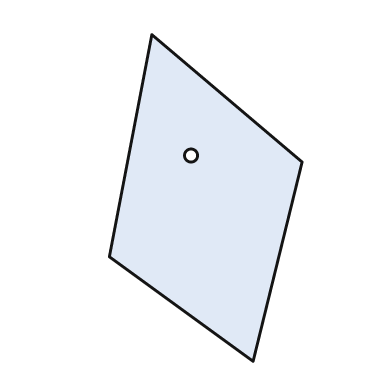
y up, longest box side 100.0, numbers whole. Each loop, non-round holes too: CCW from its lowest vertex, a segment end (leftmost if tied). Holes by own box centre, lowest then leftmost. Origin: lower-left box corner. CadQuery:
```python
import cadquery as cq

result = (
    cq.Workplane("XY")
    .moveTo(44.0, 0.0)
    .lineTo(59.0, 61.0)
    .lineTo(13.0, 100.0)
    .lineTo(0.0, 32.0)
    .close()
    .moveTo(25.0, 63.0)
    .circle(2.0)
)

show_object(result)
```